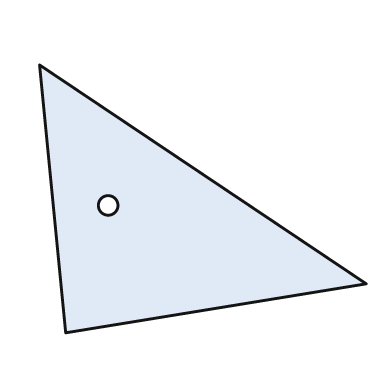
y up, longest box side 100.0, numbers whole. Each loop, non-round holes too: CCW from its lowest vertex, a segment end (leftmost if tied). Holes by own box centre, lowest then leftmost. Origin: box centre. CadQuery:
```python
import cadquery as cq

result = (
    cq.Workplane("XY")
    .moveTo(-42.0, -41.0)
    .lineTo(50.0, -26.0)
    .lineTo(-50.0, 41.0)
    .close()
    .moveTo(-29.0, -2.0)
    .circle(3.0)
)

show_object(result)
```